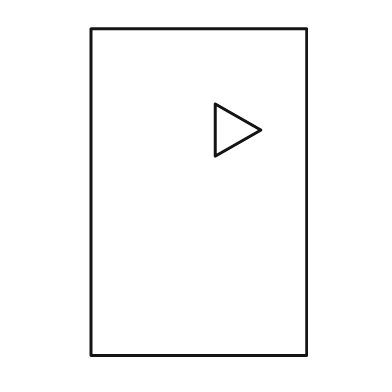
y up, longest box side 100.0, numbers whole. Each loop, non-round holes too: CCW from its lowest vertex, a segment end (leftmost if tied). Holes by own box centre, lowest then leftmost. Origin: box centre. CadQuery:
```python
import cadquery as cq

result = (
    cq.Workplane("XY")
    .moveTo(-33.0, -50.0)
    .lineTo(33.0, -50.0)
    .lineTo(33.0, 50.0)
    .lineTo(-33.0, 50.0)
    .close()
    .moveTo(5.0, 11.0)
    .lineTo(19.0, 19.0)
    .lineTo(5.0, 27.0)
    .close()
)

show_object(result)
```